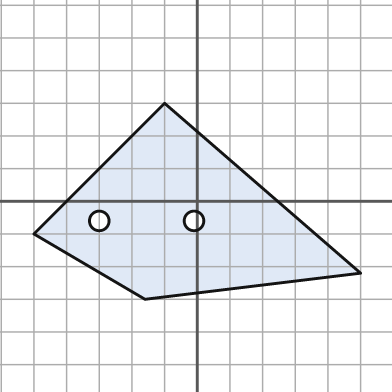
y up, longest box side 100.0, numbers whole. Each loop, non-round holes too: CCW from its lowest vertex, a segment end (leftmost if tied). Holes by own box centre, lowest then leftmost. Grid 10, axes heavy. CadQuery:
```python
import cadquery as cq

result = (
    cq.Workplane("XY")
    .moveTo(-16.0, -30.0)
    .lineTo(50.0, -22.0)
    .lineTo(-10.0, 30.0)
    .lineTo(-50.0, -10.0)
    .close()
    .moveTo(-30.0, -6.0)
    .circle(3.0)
    .moveTo(-1.0, -6.0)
    .circle(3.0)
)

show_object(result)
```